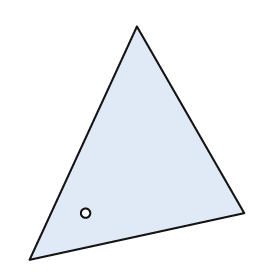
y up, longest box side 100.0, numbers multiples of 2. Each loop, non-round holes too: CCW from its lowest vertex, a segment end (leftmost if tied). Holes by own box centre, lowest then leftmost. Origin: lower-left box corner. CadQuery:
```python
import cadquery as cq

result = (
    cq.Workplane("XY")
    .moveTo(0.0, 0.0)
    .lineTo(92.0, 20.0)
    .lineTo(46.0, 100.0)
    .close()
    .moveTo(24.0, 20.0)
    .circle(2.0)
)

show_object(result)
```